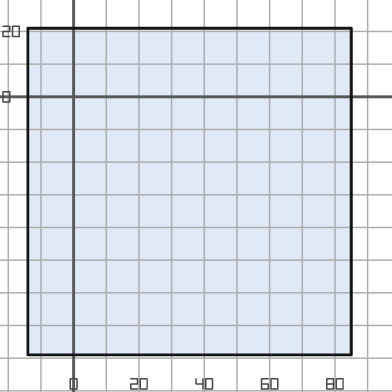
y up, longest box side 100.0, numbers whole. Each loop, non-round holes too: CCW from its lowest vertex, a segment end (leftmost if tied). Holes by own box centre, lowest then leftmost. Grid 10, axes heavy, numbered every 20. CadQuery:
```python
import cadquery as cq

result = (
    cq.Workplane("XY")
    .moveTo(-14.0, -79.0)
    .lineTo(85.0, -79.0)
    .lineTo(85.0, 21.0)
    .lineTo(-14.0, 21.0)
    .close()
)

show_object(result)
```